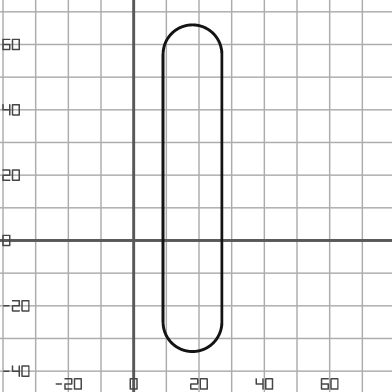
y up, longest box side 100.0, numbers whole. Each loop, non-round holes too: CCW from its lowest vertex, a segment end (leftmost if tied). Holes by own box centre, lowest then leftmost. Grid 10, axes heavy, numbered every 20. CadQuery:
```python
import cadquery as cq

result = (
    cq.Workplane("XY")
    .moveTo(9.0, -25.0)
    .threePointArc((18.0, -34.0), (27.0, -25.0))
    .lineTo(27.0, 57.0)
    .threePointArc((18.0, 66.0), (9.0, 57.0))
    .close()
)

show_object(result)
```